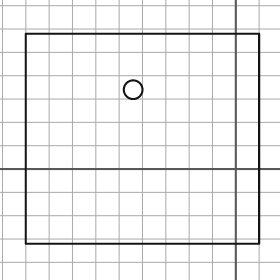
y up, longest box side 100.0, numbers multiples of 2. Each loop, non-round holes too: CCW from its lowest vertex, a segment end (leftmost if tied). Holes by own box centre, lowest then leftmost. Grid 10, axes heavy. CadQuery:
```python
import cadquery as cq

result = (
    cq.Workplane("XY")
    .moveTo(-90.0, -32.0)
    .lineTo(10.0, -32.0)
    .lineTo(10.0, 58.0)
    .lineTo(-90.0, 58.0)
    .close()
    .moveTo(-44.0, 34.0)
    .circle(4.0)
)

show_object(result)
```